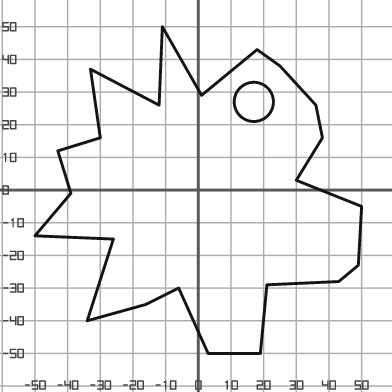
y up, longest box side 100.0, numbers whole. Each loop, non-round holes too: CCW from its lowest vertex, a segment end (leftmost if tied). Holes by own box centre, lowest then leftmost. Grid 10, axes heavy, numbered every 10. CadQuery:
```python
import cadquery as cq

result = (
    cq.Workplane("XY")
    .moveTo(3.0, -50.0)
    .lineTo(19.0, -50.0)
    .lineTo(21.0, -29.0)
    .lineTo(43.0, -28.0)
    .lineTo(49.0, -23.0)
    .lineTo(50.0, -5.0)
    .lineTo(30.0, 3.0)
    .lineTo(38.0, 16.0)
    .lineTo(36.0, 26.0)
    .lineTo(25.0, 38.0)
    .lineTo(18.0, 43.0)
    .lineTo(1.0, 29.0)
    .lineTo(-11.0, 50.0)
    .lineTo(-12.0, 26.0)
    .lineTo(-33.0, 37.0)
    .lineTo(-30.0, 16.0)
    .lineTo(-43.0, 12.0)
    .lineTo(-39.0, -1.0)
    .lineTo(-50.0, -14.0)
    .lineTo(-26.0, -15.0)
    .lineTo(-34.0, -40.0)
    .lineTo(-16.0, -35.0)
    .lineTo(-6.0, -30.0)
    .close()
    .moveTo(17.0, 27.0)
    .circle(6.0)
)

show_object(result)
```